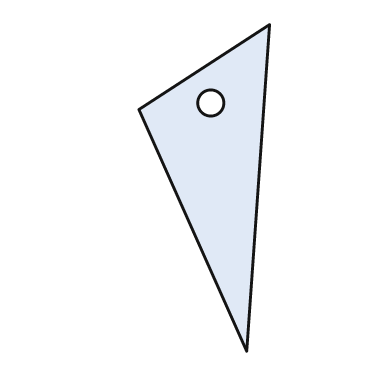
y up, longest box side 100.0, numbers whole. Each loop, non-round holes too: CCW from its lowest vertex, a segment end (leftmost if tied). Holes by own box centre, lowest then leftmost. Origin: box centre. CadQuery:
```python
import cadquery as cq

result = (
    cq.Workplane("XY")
    .moveTo(13.0, -50.0)
    .lineTo(20.0, 50.0)
    .lineTo(-20.0, 24.0)
    .close()
    .moveTo(2.0, 26.0)
    .circle(4.0)
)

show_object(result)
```